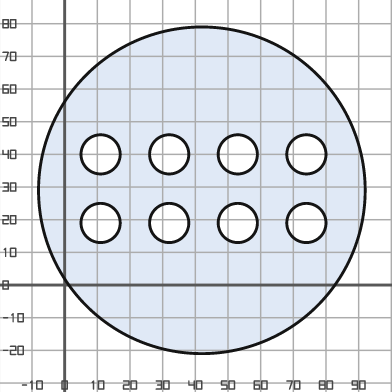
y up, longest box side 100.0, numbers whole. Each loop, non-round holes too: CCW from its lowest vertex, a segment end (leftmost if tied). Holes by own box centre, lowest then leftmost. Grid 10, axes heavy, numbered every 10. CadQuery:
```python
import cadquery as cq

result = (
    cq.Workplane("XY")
    .moveTo(42.0, 29.0)
    .circle(50.0)
    .moveTo(11.0, 19.0)
    .circle(6.0)
    .moveTo(32.0, 19.0)
    .circle(6.0)
    .moveTo(53.0, 19.0)
    .circle(6.0)
    .moveTo(74.0, 19.0)
    .circle(6.0)
    .moveTo(11.0, 40.0)
    .circle(6.0)
    .moveTo(32.0, 40.0)
    .circle(6.0)
    .moveTo(53.0, 40.0)
    .circle(6.0)
    .moveTo(74.0, 40.0)
    .circle(6.0)
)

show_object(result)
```